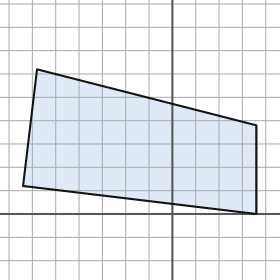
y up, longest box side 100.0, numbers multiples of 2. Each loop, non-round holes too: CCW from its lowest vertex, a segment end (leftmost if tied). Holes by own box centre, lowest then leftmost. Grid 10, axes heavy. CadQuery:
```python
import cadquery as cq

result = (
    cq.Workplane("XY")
    .moveTo(36.0, 0.0)
    .lineTo(36.0, 38.0)
    .lineTo(-58.0, 62.0)
    .lineTo(-64.0, 12.0)
    .close()
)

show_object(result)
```